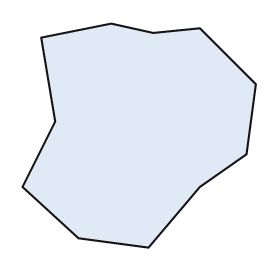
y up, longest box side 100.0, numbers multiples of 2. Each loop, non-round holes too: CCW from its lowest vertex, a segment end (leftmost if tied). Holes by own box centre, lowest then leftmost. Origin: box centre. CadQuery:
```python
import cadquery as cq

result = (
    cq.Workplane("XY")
    .moveTo(4.0, -48.0)
    .lineTo(26.0, -22.0)
    .lineTo(46.0, -8.0)
    .lineTo(50.0, 22.0)
    .lineTo(26.0, 46.0)
    .lineTo(6.0, 44.0)
    .lineTo(-12.0, 48.0)
    .lineTo(-42.0, 42.0)
    .lineTo(-36.0, 6.0)
    .lineTo(-50.0, -22.0)
    .lineTo(-26.0, -44.0)
    .close()
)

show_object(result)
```